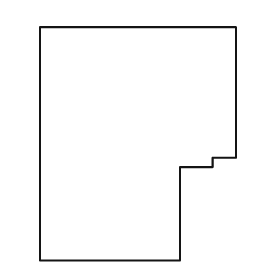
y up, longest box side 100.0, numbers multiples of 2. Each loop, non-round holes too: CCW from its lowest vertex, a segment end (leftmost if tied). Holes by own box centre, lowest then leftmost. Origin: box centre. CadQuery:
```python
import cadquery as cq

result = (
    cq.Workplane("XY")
    .moveTo(-42.0, -50.0)
    .lineTo(18.0, -50.0)
    .lineTo(18.0, -10.0)
    .lineTo(32.0, -10.0)
    .lineTo(32.0, -6.0)
    .lineTo(42.0, -6.0)
    .lineTo(42.0, 50.0)
    .lineTo(-42.0, 50.0)
    .close()
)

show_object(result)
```